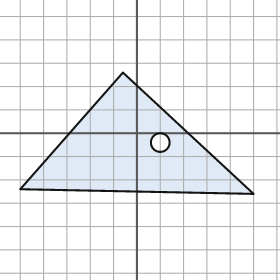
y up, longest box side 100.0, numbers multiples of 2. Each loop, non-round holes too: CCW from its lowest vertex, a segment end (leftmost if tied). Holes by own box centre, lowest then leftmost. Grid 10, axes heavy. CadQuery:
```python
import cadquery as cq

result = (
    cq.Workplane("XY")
    .moveTo(50.0, -26.0)
    .lineTo(-6.0, 26.0)
    .lineTo(-50.0, -24.0)
    .close()
    .moveTo(10.0, -4.0)
    .circle(4.0)
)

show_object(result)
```